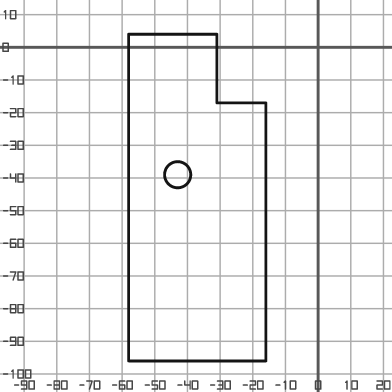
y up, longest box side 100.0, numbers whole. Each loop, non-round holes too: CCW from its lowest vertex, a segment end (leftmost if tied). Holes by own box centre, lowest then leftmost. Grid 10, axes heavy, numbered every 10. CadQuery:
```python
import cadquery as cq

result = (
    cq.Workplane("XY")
    .moveTo(-58.0, -96.0)
    .lineTo(-16.0, -96.0)
    .lineTo(-16.0, -17.0)
    .lineTo(-31.0, -17.0)
    .lineTo(-31.0, 4.0)
    .lineTo(-58.0, 4.0)
    .close()
    .moveTo(-43.0, -39.0)
    .circle(4.0)
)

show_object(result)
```